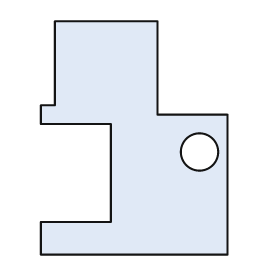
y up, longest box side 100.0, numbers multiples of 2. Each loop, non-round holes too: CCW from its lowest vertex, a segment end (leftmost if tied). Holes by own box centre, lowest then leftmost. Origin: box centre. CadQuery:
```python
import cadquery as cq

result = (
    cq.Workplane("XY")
    .moveTo(-40.0, -50.0)
    .lineTo(40.0, -50.0)
    .lineTo(40.0, 10.0)
    .lineTo(10.0, 10.0)
    .lineTo(10.0, 50.0)
    .lineTo(-34.0, 50.0)
    .lineTo(-34.0, 14.0)
    .lineTo(-40.0, 14.0)
    .lineTo(-40.0, 6.0)
    .lineTo(-10.0, 6.0)
    .lineTo(-10.0, -36.0)
    .lineTo(-40.0, -36.0)
    .close()
    .moveTo(28.0, -6.0)
    .circle(8.0)
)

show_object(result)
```